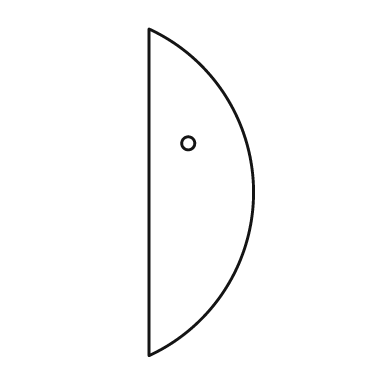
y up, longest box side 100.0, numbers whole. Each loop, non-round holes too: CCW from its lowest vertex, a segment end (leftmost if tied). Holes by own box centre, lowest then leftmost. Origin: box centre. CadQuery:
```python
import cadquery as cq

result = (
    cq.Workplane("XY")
    .moveTo(-16.0, -50.0)
    .threePointArc((16.0, 0.0), (-16.0, 50.0))
    .close()
    .moveTo(-4.0, 15.0)
    .circle(2.0)
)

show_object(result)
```